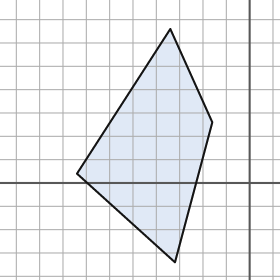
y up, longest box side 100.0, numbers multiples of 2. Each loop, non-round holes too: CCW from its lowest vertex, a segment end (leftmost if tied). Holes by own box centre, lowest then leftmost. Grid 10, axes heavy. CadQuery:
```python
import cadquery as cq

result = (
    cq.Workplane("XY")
    .moveTo(-32.0, -34.0)
    .lineTo(-16.0, 26.0)
    .lineTo(-34.0, 66.0)
    .lineTo(-74.0, 4.0)
    .close()
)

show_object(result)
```